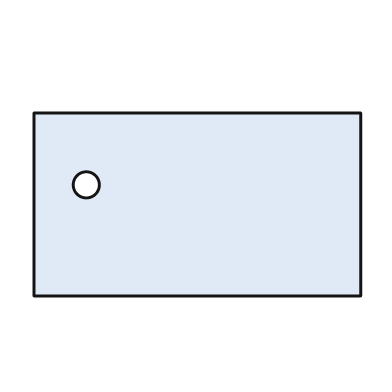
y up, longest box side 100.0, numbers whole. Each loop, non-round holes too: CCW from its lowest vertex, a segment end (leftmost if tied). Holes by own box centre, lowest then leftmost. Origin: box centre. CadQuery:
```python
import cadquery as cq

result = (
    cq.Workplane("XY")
    .moveTo(-50.0, -28.0)
    .lineTo(50.0, -28.0)
    .lineTo(50.0, 28.0)
    .lineTo(-50.0, 28.0)
    .close()
    .moveTo(-34.0, 6.0)
    .circle(4.0)
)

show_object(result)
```